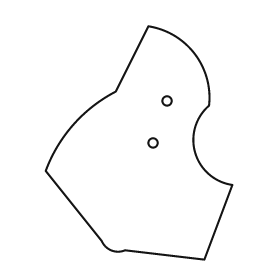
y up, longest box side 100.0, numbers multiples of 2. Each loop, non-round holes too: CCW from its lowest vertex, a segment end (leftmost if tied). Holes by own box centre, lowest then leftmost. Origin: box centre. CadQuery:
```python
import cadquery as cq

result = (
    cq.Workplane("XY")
    .moveTo(28.0, -50.0)
    .lineTo(40.0, -18.0)
    .threePointArc((24.0, -4.0), (30.0, 16.0))
    .threePointArc((24.0, 38.0), (4.0, 50.0))
    .lineTo(-10.0, 22.0)
    .threePointArc((-28.0, 8.0), (-40.0, -12.0))
    .lineTo(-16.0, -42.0)
    .threePointArc((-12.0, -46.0), (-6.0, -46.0))
    .close()
    .moveTo(6.0, 0.0)
    .circle(2.0)
    .moveTo(12.0, 18.0)
    .circle(2.0)
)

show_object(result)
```